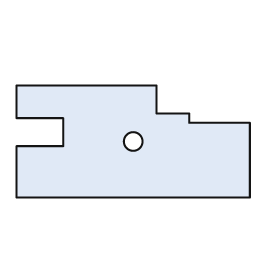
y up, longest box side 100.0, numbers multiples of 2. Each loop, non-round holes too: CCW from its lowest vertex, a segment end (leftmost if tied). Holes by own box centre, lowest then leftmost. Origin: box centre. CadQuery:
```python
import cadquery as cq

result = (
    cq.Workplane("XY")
    .moveTo(-50.0, -24.0)
    .lineTo(50.0, -24.0)
    .lineTo(50.0, 8.0)
    .lineTo(24.0, 8.0)
    .lineTo(24.0, 12.0)
    .lineTo(10.0, 12.0)
    .lineTo(10.0, 24.0)
    .lineTo(-50.0, 24.0)
    .lineTo(-50.0, 10.0)
    .lineTo(-30.0, 10.0)
    .lineTo(-30.0, -2.0)
    .lineTo(-50.0, -2.0)
    .close()
    .moveTo(0.0, 0.0)
    .circle(4.0)
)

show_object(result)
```